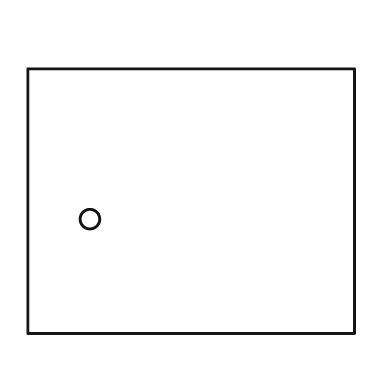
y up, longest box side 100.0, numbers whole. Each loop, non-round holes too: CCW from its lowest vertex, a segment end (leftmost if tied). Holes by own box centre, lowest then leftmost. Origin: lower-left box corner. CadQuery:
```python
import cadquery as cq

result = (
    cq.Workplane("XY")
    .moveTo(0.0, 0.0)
    .lineTo(100.0, 0.0)
    .lineTo(100.0, 81.0)
    .lineTo(0.0, 81.0)
    .close()
    .moveTo(19.0, 35.0)
    .circle(3.0)
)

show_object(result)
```